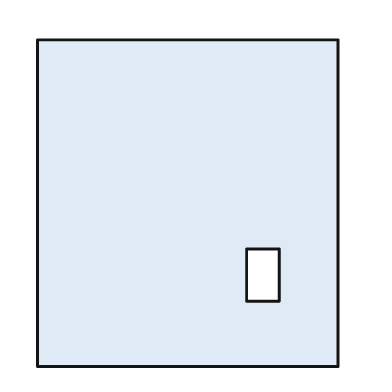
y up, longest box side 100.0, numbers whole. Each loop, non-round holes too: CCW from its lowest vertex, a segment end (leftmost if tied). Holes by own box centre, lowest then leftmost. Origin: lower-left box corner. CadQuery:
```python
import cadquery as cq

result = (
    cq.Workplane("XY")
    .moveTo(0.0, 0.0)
    .lineTo(92.0, 0.0)
    .lineTo(92.0, 100.0)
    .lineTo(0.0, 100.0)
    .close()
    .moveTo(64.0, 20.0)
    .lineTo(74.0, 20.0)
    .lineTo(74.0, 36.0)
    .lineTo(64.0, 36.0)
    .close()
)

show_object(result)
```